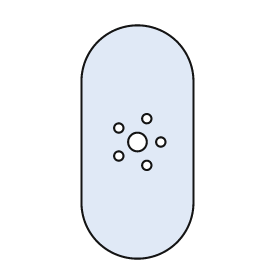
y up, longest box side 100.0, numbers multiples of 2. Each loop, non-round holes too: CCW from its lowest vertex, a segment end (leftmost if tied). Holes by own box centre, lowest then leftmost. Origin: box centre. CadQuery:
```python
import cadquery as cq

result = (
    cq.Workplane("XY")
    .moveTo(-24.0, -26.0)
    .threePointArc((0.0, -50.0), (24.0, -26.0))
    .lineTo(24.0, 26.0)
    .threePointArc((0.0, 50.0), (-24.0, 26.0))
    .close()
    .moveTo(4.0, -10.0)
    .circle(2.0)
    .moveTo(-8.0, -6.0)
    .circle(2.0)
    .moveTo(0.0, 0.0)
    .circle(4.0)
    .moveTo(10.0, 0.0)
    .circle(2.0)
    .moveTo(-8.0, 6.0)
    .circle(2.0)
    .moveTo(4.0, 10.0)
    .circle(2.0)
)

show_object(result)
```